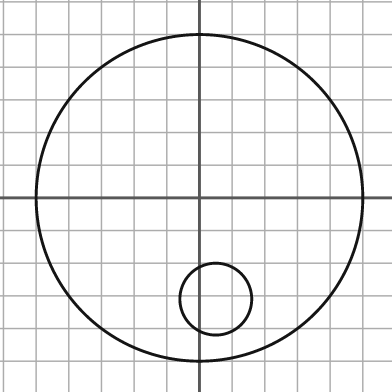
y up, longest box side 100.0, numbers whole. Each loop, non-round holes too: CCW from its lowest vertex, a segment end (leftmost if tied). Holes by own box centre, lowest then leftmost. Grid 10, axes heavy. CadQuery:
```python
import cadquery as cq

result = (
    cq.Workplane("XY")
    .moveTo(0.0, 0.0)
    .circle(50.0)
    .moveTo(5.0, -31.0)
    .circle(11.0)
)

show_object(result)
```